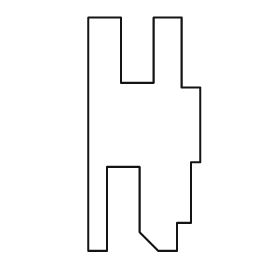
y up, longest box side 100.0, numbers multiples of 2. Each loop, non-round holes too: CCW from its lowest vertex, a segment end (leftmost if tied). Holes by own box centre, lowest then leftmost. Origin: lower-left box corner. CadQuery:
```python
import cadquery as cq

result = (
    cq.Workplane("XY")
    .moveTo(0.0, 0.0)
    .lineTo(8.0, 0.0)
    .lineTo(8.0, 36.0)
    .lineTo(22.0, 36.0)
    .lineTo(22.0, 8.0)
    .lineTo(30.0, 0.0)
    .lineTo(38.0, 0.0)
    .lineTo(38.0, 12.0)
    .lineTo(44.0, 12.0)
    .lineTo(44.0, 38.0)
    .lineTo(48.0, 38.0)
    .lineTo(48.0, 70.0)
    .lineTo(40.0, 70.0)
    .lineTo(40.0, 100.0)
    .lineTo(28.0, 100.0)
    .lineTo(28.0, 72.0)
    .lineTo(14.0, 72.0)
    .lineTo(14.0, 100.0)
    .lineTo(0.0, 100.0)
    .close()
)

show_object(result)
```